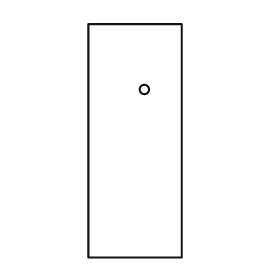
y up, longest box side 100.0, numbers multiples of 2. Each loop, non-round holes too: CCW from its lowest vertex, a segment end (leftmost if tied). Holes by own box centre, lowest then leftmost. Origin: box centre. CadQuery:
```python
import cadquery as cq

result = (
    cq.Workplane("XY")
    .moveTo(-20.0, -50.0)
    .lineTo(20.0, -50.0)
    .lineTo(20.0, 50.0)
    .lineTo(-20.0, 50.0)
    .close()
    .moveTo(4.0, 22.0)
    .circle(2.0)
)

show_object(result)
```